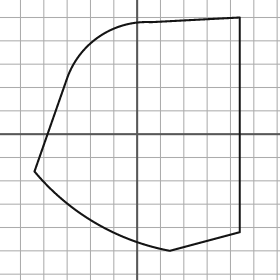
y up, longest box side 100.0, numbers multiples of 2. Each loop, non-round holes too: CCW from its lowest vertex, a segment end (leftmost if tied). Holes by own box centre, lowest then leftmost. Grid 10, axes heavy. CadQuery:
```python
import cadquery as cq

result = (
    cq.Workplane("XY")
    .moveTo(14.0, -50.0)
    .lineTo(44.0, -42.0)
    .lineTo(44.0, 50.0)
    .lineTo(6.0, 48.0)
    .threePointArc((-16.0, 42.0), (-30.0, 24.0))
    .lineTo(-44.0, -16.0)
    .threePointArc((-18.0, -38.0), (14.0, -50.0))
    .close()
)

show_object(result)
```